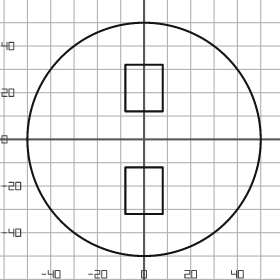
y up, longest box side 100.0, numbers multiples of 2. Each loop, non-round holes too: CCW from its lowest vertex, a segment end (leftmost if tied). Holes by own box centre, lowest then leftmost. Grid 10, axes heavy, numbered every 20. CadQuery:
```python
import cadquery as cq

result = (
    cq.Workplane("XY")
    .moveTo(0.0, 0.0)
    .circle(50.0)
    .moveTo(-8.0, -32.0)
    .lineTo(8.0, -32.0)
    .lineTo(8.0, -12.0)
    .lineTo(-8.0, -12.0)
    .close()
    .moveTo(-8.0, 12.0)
    .lineTo(8.0, 12.0)
    .lineTo(8.0, 32.0)
    .lineTo(-8.0, 32.0)
    .close()
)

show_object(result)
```